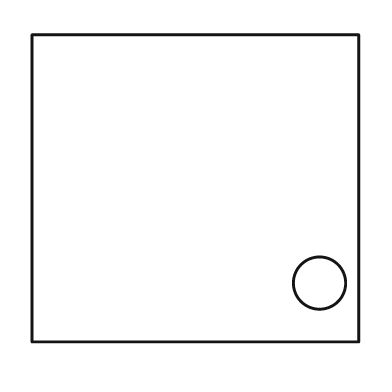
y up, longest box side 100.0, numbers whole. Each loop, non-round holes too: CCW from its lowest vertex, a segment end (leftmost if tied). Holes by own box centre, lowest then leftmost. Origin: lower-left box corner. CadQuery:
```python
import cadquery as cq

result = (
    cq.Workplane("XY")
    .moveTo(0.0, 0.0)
    .lineTo(100.0, 0.0)
    .lineTo(100.0, 94.0)
    .lineTo(0.0, 94.0)
    .close()
    .moveTo(88.0, 18.0)
    .circle(8.0)
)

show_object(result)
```